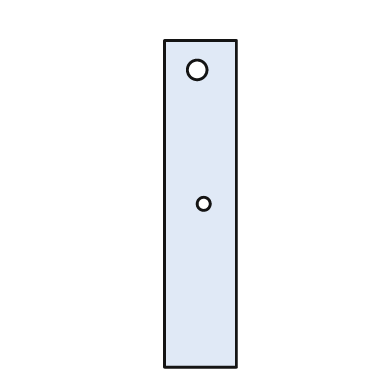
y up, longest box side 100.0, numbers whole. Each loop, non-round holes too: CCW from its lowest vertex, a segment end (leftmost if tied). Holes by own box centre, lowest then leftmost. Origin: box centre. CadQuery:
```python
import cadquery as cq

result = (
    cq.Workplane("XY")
    .moveTo(-11.0, -50.0)
    .lineTo(11.0, -50.0)
    .lineTo(11.0, 50.0)
    .lineTo(-11.0, 50.0)
    .close()
    .moveTo(1.0, 0.0)
    .circle(2.0)
    .moveTo(-1.0, 41.0)
    .circle(3.0)
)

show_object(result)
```